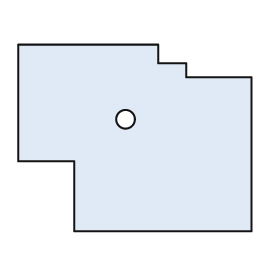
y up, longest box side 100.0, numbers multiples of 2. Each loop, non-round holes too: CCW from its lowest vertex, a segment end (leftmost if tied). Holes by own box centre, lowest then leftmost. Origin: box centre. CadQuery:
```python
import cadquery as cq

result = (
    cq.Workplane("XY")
    .moveTo(-26.0, -40.0)
    .lineTo(50.0, -40.0)
    .lineTo(50.0, 26.0)
    .lineTo(22.0, 26.0)
    .lineTo(22.0, 32.0)
    .lineTo(10.0, 32.0)
    .lineTo(10.0, 40.0)
    .lineTo(-50.0, 40.0)
    .lineTo(-50.0, -10.0)
    .lineTo(-26.0, -10.0)
    .close()
    .moveTo(-4.0, 8.0)
    .circle(4.0)
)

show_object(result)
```